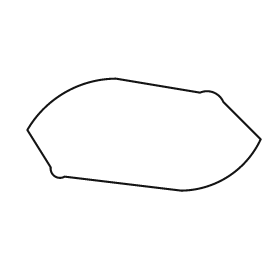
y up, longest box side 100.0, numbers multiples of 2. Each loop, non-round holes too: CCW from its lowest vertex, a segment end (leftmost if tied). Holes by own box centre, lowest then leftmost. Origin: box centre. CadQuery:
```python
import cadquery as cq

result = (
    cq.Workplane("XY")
    .moveTo(16.0, -24.0)
    .threePointArc((36.0, -18.0), (50.0, -2.0))
    .lineTo(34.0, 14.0)
    .threePointArc((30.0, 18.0), (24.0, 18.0))
    .lineTo(-12.0, 24.0)
    .threePointArc((-34.0, 18.0), (-50.0, 2.0))
    .lineTo(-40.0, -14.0)
    .threePointArc((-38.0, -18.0), (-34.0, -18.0))
    .close()
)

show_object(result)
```